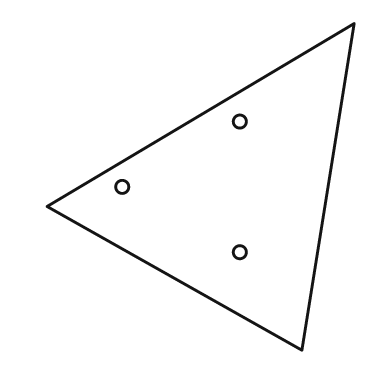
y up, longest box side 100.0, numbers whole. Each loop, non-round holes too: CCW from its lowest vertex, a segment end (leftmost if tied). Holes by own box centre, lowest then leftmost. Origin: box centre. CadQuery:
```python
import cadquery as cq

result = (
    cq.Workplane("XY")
    .moveTo(31.0, -50.0)
    .lineTo(47.0, 50.0)
    .lineTo(-47.0, -6.0)
    .close()
    .moveTo(12.0, -20.0)
    .circle(2.0)
    .moveTo(-24.0, 0.0)
    .circle(2.0)
    .moveTo(12.0, 20.0)
    .circle(2.0)
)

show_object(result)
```